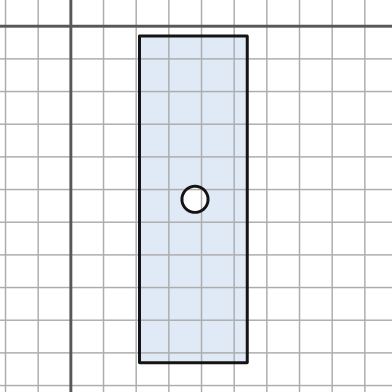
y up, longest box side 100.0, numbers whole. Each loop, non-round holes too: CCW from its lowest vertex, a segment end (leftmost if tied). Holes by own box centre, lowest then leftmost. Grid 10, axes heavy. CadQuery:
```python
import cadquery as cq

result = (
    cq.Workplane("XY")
    .moveTo(21.0, -103.0)
    .lineTo(54.0, -103.0)
    .lineTo(54.0, -3.0)
    .lineTo(21.0, -3.0)
    .close()
    .moveTo(38.0, -53.0)
    .circle(4.0)
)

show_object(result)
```